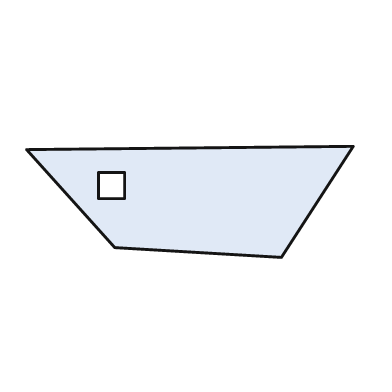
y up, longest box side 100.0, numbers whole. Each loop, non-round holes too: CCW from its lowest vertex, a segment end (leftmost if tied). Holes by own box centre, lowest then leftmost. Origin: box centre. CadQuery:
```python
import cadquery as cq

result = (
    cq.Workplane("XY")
    .moveTo(28.0, -17.0)
    .lineTo(50.0, 17.0)
    .lineTo(-50.0, 16.0)
    .lineTo(-23.0, -14.0)
    .close()
    .moveTo(-28.0, 1.0)
    .lineTo(-20.0, 1.0)
    .lineTo(-20.0, 9.0)
    .lineTo(-28.0, 9.0)
    .close()
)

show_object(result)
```